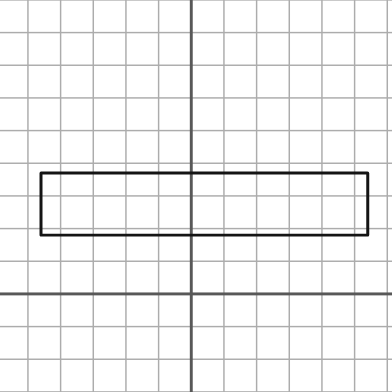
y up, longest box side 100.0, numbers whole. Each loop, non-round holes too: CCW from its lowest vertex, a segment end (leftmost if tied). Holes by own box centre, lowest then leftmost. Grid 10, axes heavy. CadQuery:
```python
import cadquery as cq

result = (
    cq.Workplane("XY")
    .moveTo(-46.0, 18.0)
    .lineTo(54.0, 18.0)
    .lineTo(54.0, 37.0)
    .lineTo(-46.0, 37.0)
    .close()
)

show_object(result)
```